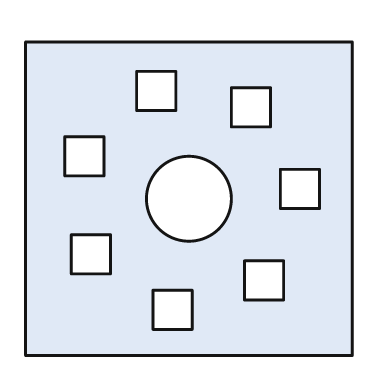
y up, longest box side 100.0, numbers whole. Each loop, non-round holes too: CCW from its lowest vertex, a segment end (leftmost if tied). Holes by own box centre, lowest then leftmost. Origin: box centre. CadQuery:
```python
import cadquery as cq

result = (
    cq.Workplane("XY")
    .moveTo(-50.0, -48.0)
    .lineTo(50.0, -48.0)
    .lineTo(50.0, 48.0)
    .lineTo(-50.0, 48.0)
    .close()
    .moveTo(-11.0, -40.0)
    .lineTo(1.0, -40.0)
    .lineTo(1.0, -28.0)
    .lineTo(-11.0, -28.0)
    .close()
    .moveTo(17.0, -31.0)
    .lineTo(29.0, -31.0)
    .lineTo(29.0, -19.0)
    .lineTo(17.0, -19.0)
    .close()
    .moveTo(-36.0, -23.0)
    .lineTo(-24.0, -23.0)
    .lineTo(-24.0, -11.0)
    .lineTo(-36.0, -11.0)
    .close()
    .moveTo(0.0, 0.0)
    .circle(13.0)
    .moveTo(28.0, -3.0)
    .lineTo(40.0, -3.0)
    .lineTo(40.0, 9.0)
    .lineTo(28.0, 9.0)
    .close()
    .moveTo(-38.0, 7.0)
    .lineTo(-26.0, 7.0)
    .lineTo(-26.0, 19.0)
    .lineTo(-38.0, 19.0)
    .close()
    .moveTo(13.0, 22.0)
    .lineTo(25.0, 22.0)
    .lineTo(25.0, 34.0)
    .lineTo(13.0, 34.0)
    .close()
    .moveTo(-16.0, 27.0)
    .lineTo(-4.0, 27.0)
    .lineTo(-4.0, 39.0)
    .lineTo(-16.0, 39.0)
    .close()
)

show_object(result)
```